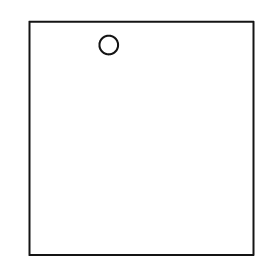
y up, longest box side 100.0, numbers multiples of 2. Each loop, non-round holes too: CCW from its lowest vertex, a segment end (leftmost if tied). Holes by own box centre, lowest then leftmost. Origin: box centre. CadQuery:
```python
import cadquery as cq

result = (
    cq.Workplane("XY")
    .moveTo(-48.0, -50.0)
    .lineTo(48.0, -50.0)
    .lineTo(48.0, 50.0)
    .lineTo(-48.0, 50.0)
    .close()
    .moveTo(-14.0, 40.0)
    .circle(4.0)
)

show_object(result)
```